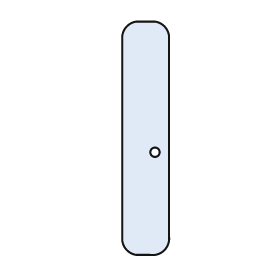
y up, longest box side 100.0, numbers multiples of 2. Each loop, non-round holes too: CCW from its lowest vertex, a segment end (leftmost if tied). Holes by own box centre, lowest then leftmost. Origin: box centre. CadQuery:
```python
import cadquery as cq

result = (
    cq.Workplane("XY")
    .moveTo(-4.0, -50.0)
    .lineTo(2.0, -50.0)
    .threePointArc((8.0, -48.0), (10.0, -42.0))
    .lineTo(10.0, 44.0)
    .threePointArc((8.0, 48.0), (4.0, 50.0))
    .lineTo(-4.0, 50.0)
    .threePointArc((-8.0, 48.0), (-10.0, 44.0))
    .lineTo(-10.0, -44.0)
    .threePointArc((-8.0, -48.0), (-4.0, -50.0))
    .close()
    .moveTo(4.0, -6.0)
    .circle(2.0)
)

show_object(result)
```